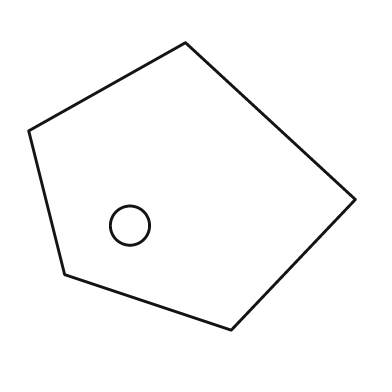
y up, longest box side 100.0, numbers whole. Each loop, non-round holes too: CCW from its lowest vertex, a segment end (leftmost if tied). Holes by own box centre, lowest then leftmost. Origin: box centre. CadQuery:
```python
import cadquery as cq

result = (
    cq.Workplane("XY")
    .moveTo(12.0, -44.0)
    .lineTo(50.0, -4.0)
    .lineTo(-2.0, 44.0)
    .lineTo(-50.0, 17.0)
    .lineTo(-39.0, -27.0)
    .close()
    .moveTo(-19.0, -12.0)
    .circle(6.0)
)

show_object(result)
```